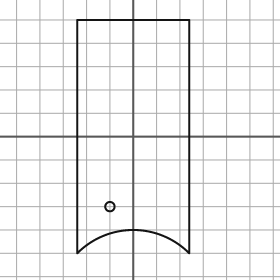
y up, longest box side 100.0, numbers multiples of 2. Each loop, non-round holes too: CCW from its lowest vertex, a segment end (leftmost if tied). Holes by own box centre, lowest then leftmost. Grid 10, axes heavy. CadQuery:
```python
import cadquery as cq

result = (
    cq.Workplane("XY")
    .moveTo(-24.0, -50.0)
    .threePointArc((0.0, -40.0), (24.0, -50.0))
    .lineTo(24.0, 50.0)
    .lineTo(-24.0, 50.0)
    .close()
    .moveTo(-10.0, -30.0)
    .circle(2.0)
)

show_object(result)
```